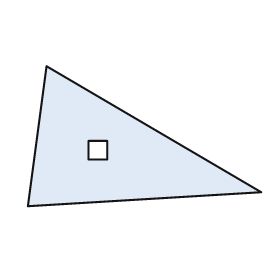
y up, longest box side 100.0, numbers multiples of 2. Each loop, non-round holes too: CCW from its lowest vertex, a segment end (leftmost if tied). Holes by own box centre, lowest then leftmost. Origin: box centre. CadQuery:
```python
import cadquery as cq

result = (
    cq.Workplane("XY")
    .moveTo(-50.0, -30.0)
    .lineTo(50.0, -24.0)
    .lineTo(-42.0, 30.0)
    .close()
    .moveTo(-24.0, -10.0)
    .lineTo(-16.0, -10.0)
    .lineTo(-16.0, -2.0)
    .lineTo(-24.0, -2.0)
    .close()
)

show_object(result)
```